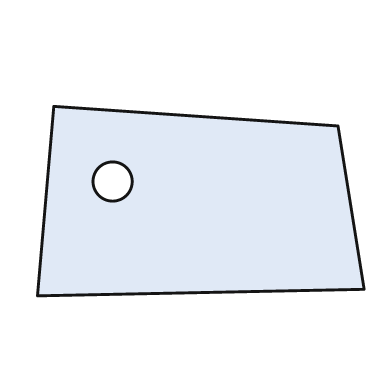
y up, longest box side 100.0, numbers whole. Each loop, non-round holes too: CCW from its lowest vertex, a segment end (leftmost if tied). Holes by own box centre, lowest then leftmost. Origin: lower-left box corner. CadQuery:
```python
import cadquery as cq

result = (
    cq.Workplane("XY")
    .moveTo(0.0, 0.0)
    .lineTo(100.0, 2.0)
    .lineTo(92.0, 52.0)
    .lineTo(5.0, 58.0)
    .close()
    .moveTo(23.0, 35.0)
    .circle(6.0)
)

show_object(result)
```